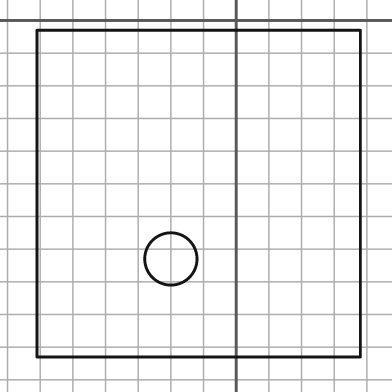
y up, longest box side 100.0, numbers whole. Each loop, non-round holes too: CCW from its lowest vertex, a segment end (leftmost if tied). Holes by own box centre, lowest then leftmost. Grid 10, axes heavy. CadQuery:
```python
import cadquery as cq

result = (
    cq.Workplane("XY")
    .moveTo(-61.0, -103.0)
    .lineTo(38.0, -103.0)
    .lineTo(38.0, -3.0)
    .lineTo(-61.0, -3.0)
    .close()
    .moveTo(-20.0, -73.0)
    .circle(8.0)
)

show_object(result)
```